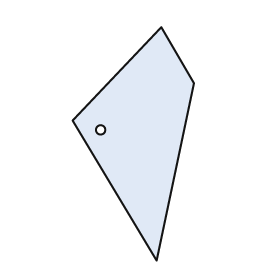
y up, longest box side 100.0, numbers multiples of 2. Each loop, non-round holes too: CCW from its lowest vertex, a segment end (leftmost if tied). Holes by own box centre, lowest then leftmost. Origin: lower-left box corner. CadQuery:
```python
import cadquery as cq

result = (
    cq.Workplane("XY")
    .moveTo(36.0, 0.0)
    .lineTo(52.0, 76.0)
    .lineTo(38.0, 100.0)
    .lineTo(0.0, 60.0)
    .close()
    .moveTo(12.0, 56.0)
    .circle(2.0)
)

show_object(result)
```